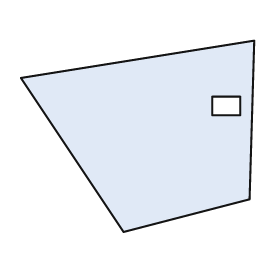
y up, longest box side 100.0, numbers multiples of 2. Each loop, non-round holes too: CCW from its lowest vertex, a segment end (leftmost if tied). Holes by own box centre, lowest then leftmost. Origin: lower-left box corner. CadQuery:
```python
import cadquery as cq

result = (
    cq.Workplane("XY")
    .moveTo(44.0, 0.0)
    .lineTo(98.0, 14.0)
    .lineTo(100.0, 82.0)
    .lineTo(0.0, 66.0)
    .close()
    .moveTo(82.0, 50.0)
    .lineTo(94.0, 50.0)
    .lineTo(94.0, 58.0)
    .lineTo(82.0, 58.0)
    .close()
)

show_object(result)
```